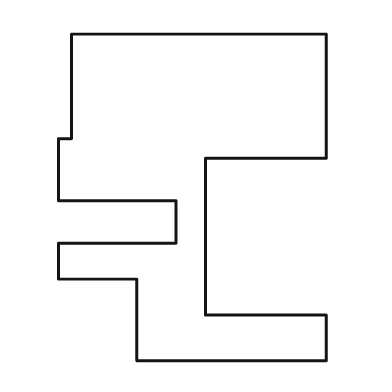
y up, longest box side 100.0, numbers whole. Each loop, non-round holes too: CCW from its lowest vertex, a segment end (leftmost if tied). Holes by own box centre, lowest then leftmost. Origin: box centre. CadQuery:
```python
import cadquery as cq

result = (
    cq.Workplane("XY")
    .moveTo(-17.0, -50.0)
    .lineTo(41.0, -50.0)
    .lineTo(41.0, -36.0)
    .lineTo(4.0, -36.0)
    .lineTo(4.0, 12.0)
    .lineTo(41.0, 12.0)
    .lineTo(41.0, 50.0)
    .lineTo(-37.0, 50.0)
    .lineTo(-37.0, 18.0)
    .lineTo(-41.0, 18.0)
    .lineTo(-41.0, -1.0)
    .lineTo(-5.0, -1.0)
    .lineTo(-5.0, -14.0)
    .lineTo(-41.0, -14.0)
    .lineTo(-41.0, -25.0)
    .lineTo(-17.0, -25.0)
    .close()
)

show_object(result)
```